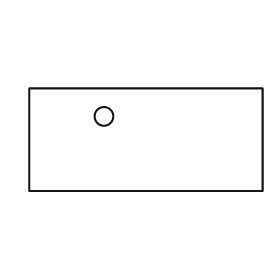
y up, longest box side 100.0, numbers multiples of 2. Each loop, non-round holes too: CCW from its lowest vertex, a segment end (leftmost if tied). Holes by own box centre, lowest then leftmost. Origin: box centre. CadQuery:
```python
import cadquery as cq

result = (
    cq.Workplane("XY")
    .moveTo(-50.0, -22.0)
    .lineTo(50.0, -22.0)
    .lineTo(50.0, 22.0)
    .lineTo(-50.0, 22.0)
    .close()
    .moveTo(-18.0, 10.0)
    .circle(4.0)
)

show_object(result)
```